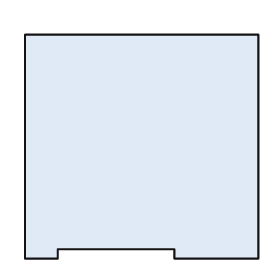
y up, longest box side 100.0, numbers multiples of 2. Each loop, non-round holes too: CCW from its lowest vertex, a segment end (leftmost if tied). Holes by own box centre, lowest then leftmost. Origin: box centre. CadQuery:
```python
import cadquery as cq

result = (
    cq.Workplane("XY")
    .moveTo(-50.0, -48.0)
    .lineTo(-36.0, -48.0)
    .lineTo(-36.0, -44.0)
    .lineTo(14.0, -44.0)
    .lineTo(14.0, -48.0)
    .lineTo(50.0, -48.0)
    .lineTo(50.0, 48.0)
    .lineTo(-50.0, 48.0)
    .close()
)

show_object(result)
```